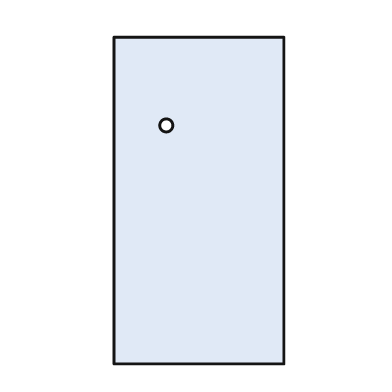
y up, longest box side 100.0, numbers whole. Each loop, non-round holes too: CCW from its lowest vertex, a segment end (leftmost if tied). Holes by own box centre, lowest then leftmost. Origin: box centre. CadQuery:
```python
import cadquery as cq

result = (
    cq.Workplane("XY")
    .moveTo(-26.0, -50.0)
    .lineTo(26.0, -50.0)
    .lineTo(26.0, 50.0)
    .lineTo(-26.0, 50.0)
    .close()
    .moveTo(-10.0, 23.0)
    .circle(2.0)
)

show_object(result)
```